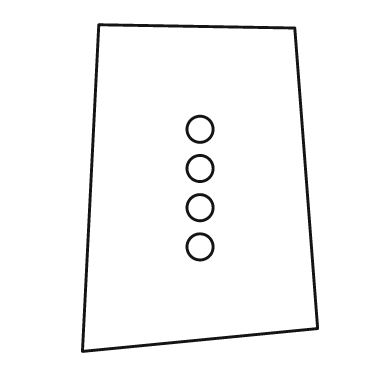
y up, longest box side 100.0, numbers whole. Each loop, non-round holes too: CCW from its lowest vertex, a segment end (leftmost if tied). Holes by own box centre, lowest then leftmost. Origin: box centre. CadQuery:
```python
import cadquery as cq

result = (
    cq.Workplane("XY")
    .moveTo(-36.0, -50.0)
    .lineTo(36.0, -43.0)
    .lineTo(29.0, 49.0)
    .lineTo(-31.0, 50.0)
    .close()
    .moveTo(0.0, -18.0)
    .circle(4.0)
    .moveTo(0.0, -6.0)
    .circle(4.0)
    .moveTo(0.0, 6.0)
    .circle(4.0)
    .moveTo(0.0, 18.0)
    .circle(4.0)
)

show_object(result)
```